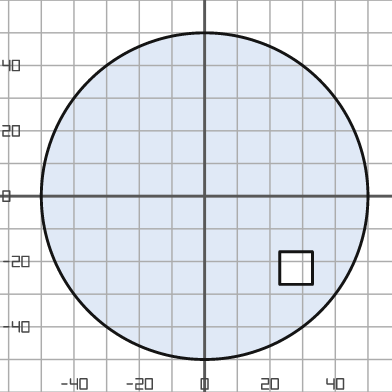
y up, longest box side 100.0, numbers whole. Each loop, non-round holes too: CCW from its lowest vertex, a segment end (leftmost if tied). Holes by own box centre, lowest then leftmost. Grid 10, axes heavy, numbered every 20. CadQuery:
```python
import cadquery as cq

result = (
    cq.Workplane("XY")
    .moveTo(0.0, 0.0)
    .circle(50.0)
    .moveTo(23.0, -27.0)
    .lineTo(33.0, -27.0)
    .lineTo(33.0, -17.0)
    .lineTo(23.0, -17.0)
    .close()
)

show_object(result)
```